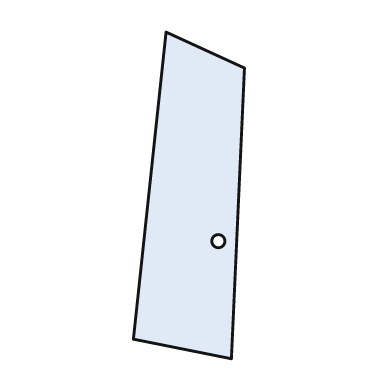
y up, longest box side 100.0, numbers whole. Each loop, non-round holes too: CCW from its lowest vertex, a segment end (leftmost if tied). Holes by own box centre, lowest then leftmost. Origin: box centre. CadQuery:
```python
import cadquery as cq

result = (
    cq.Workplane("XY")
    .moveTo(13.0, -50.0)
    .lineTo(17.0, 39.0)
    .lineTo(-7.0, 50.0)
    .lineTo(-17.0, -44.0)
    .close()
    .moveTo(9.0, -14.0)
    .circle(2.0)
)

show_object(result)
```